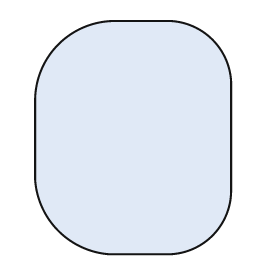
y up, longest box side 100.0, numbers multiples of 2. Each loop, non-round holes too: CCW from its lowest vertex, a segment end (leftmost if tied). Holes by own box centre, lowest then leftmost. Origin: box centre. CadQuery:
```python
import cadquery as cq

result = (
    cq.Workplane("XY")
    .moveTo(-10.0, -50.0)
    .lineTo(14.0, -50.0)
    .threePointArc((34.0, -42.0), (42.0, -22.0))
    .lineTo(42.0, 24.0)
    .threePointArc((34.0, 42.0), (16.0, 50.0))
    .lineTo(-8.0, 50.0)
    .threePointArc((-32.0, 40.0), (-42.0, 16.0))
    .lineTo(-42.0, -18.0)
    .threePointArc((-32.0, -40.0), (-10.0, -50.0))
    .close()
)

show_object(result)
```